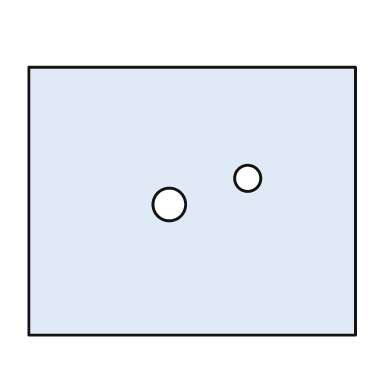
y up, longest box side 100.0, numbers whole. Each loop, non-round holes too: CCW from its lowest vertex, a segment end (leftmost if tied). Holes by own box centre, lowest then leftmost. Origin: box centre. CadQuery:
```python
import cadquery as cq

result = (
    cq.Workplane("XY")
    .moveTo(-50.0, -41.0)
    .lineTo(50.0, -41.0)
    .lineTo(50.0, 41.0)
    .lineTo(-50.0, 41.0)
    .close()
    .moveTo(-7.0, -1.0)
    .circle(5.0)
    .moveTo(17.0, 7.0)
    .circle(4.0)
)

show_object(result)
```